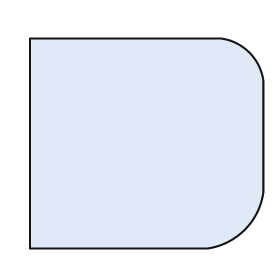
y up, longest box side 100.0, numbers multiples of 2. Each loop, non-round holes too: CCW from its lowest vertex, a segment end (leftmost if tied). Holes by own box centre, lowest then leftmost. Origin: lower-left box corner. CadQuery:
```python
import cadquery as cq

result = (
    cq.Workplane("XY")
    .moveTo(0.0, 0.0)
    .lineTo(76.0, 0.0)
    .threePointArc((92.0, 8.0), (100.0, 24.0))
    .lineTo(100.0, 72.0)
    .threePointArc((94.0, 84.0), (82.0, 90.0))
    .lineTo(0.0, 90.0)
    .close()
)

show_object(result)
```